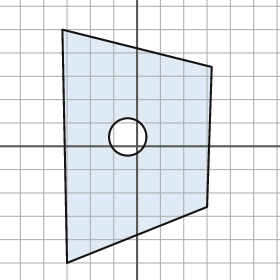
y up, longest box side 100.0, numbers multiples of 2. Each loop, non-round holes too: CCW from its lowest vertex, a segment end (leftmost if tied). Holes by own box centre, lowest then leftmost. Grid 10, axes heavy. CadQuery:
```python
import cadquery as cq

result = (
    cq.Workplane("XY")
    .moveTo(-30.0, -50.0)
    .lineTo(30.0, -26.0)
    .lineTo(32.0, 34.0)
    .lineTo(-32.0, 50.0)
    .close()
    .moveTo(-4.0, 4.0)
    .circle(8.0)
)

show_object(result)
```